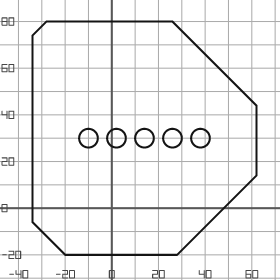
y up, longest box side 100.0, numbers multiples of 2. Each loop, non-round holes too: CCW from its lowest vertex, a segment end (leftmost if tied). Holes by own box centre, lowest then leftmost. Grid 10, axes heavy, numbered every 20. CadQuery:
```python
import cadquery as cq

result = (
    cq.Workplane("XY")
    .moveTo(-20.0, -20.0)
    .lineTo(28.0, -20.0)
    .lineTo(62.0, 14.0)
    .lineTo(62.0, 44.0)
    .lineTo(26.0, 80.0)
    .lineTo(-28.0, 80.0)
    .lineTo(-34.0, 74.0)
    .lineTo(-34.0, -6.0)
    .close()
    .moveTo(-10.0, 30.0)
    .circle(4.0)
    .moveTo(2.0, 30.0)
    .circle(4.0)
    .moveTo(14.0, 30.0)
    .circle(4.0)
    .moveTo(26.0, 30.0)
    .circle(4.0)
    .moveTo(38.0, 30.0)
    .circle(4.0)
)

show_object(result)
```